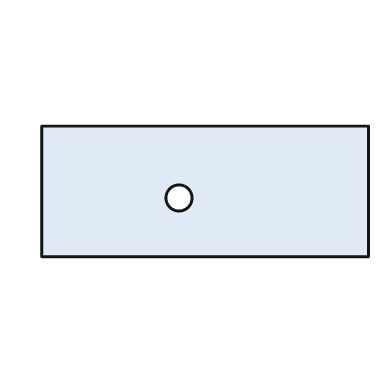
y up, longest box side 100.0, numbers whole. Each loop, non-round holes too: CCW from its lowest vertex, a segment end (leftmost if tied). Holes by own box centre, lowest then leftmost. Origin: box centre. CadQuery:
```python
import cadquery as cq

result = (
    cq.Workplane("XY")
    .moveTo(-50.0, -20.0)
    .lineTo(50.0, -20.0)
    .lineTo(50.0, 20.0)
    .lineTo(-50.0, 20.0)
    .close()
    .moveTo(-8.0, -2.0)
    .circle(4.0)
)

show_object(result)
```